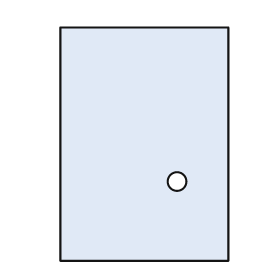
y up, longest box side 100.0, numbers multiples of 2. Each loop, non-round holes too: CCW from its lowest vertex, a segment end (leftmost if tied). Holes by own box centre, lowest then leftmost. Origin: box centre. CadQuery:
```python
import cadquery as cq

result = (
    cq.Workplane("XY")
    .moveTo(-36.0, -50.0)
    .lineTo(36.0, -50.0)
    .lineTo(36.0, 50.0)
    .lineTo(-36.0, 50.0)
    .close()
    .moveTo(14.0, -16.0)
    .circle(4.0)
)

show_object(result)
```